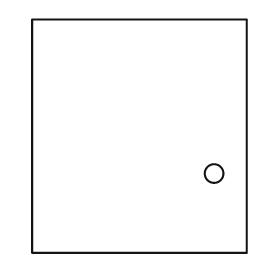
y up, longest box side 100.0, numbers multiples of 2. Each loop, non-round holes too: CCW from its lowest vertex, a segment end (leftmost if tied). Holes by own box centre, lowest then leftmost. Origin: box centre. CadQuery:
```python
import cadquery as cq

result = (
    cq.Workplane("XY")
    .moveTo(-46.0, -50.0)
    .lineTo(46.0, -50.0)
    .lineTo(46.0, 50.0)
    .lineTo(-46.0, 50.0)
    .close()
    .moveTo(32.0, -16.0)
    .circle(4.0)
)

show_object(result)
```